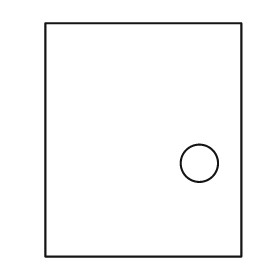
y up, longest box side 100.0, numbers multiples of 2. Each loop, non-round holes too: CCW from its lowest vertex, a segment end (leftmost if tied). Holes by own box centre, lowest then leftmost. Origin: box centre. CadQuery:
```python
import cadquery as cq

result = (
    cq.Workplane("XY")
    .moveTo(-42.0, -50.0)
    .lineTo(42.0, -50.0)
    .lineTo(42.0, 50.0)
    .lineTo(-42.0, 50.0)
    .close()
    .moveTo(24.0, -10.0)
    .circle(8.0)
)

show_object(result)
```